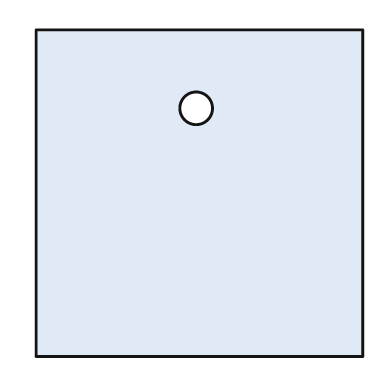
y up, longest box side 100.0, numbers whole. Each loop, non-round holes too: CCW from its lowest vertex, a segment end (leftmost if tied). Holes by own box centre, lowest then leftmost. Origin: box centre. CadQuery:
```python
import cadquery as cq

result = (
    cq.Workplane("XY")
    .moveTo(-50.0, -50.0)
    .lineTo(50.0, -50.0)
    .lineTo(50.0, 50.0)
    .lineTo(-50.0, 50.0)
    .close()
    .moveTo(-1.0, 26.0)
    .circle(5.0)
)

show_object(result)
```